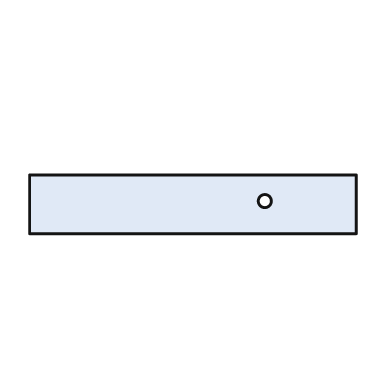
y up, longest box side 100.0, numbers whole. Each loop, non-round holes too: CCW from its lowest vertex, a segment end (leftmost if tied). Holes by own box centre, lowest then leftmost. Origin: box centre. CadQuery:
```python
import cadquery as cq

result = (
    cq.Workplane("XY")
    .moveTo(-50.0, -9.0)
    .lineTo(50.0, -9.0)
    .lineTo(50.0, 9.0)
    .lineTo(-50.0, 9.0)
    .close()
    .moveTo(22.0, 1.0)
    .circle(2.0)
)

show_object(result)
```